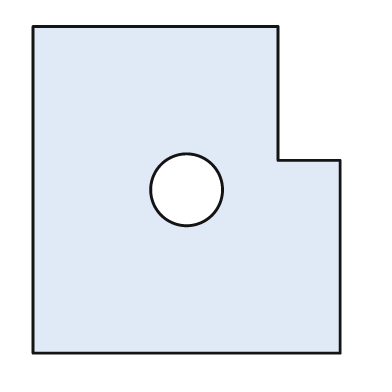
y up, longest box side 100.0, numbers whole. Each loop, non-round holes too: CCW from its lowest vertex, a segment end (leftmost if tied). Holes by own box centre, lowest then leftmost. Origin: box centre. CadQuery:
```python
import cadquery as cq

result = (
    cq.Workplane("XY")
    .moveTo(-47.0, -50.0)
    .lineTo(47.0, -50.0)
    .lineTo(47.0, 9.0)
    .lineTo(28.0, 9.0)
    .lineTo(28.0, 50.0)
    .lineTo(-47.0, 50.0)
    .close()
    .moveTo(0.0, 0.0)
    .circle(11.0)
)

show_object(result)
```